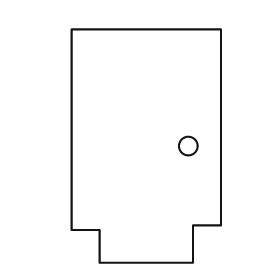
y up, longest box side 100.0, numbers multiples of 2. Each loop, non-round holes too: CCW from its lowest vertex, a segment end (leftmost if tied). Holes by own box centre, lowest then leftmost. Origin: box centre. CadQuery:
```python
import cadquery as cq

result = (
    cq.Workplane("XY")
    .moveTo(-20.0, -50.0)
    .lineTo(20.0, -50.0)
    .lineTo(20.0, -34.0)
    .lineTo(32.0, -34.0)
    .lineTo(32.0, 50.0)
    .lineTo(-32.0, 50.0)
    .lineTo(-32.0, -36.0)
    .lineTo(-20.0, -36.0)
    .close()
    .moveTo(18.0, 0.0)
    .circle(4.0)
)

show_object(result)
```